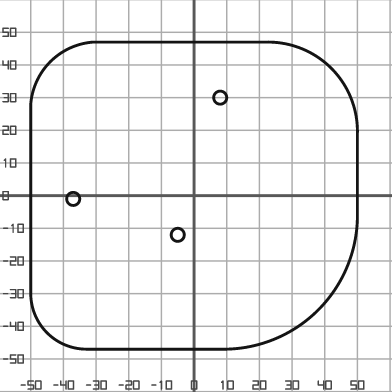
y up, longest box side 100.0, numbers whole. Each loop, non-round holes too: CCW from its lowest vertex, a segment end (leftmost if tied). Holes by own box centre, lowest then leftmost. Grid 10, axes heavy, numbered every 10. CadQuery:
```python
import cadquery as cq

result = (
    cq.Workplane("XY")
    .moveTo(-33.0, -47.0)
    .lineTo(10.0, -47.0)
    .threePointArc((38.0, -35.0), (50.0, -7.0))
    .lineTo(50.0, 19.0)
    .threePointArc((42.0, 39.0), (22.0, 47.0))
    .lineTo(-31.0, 47.0)
    .threePointArc((-44.0, 41.0), (-50.0, 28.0))
    .lineTo(-50.0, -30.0)
    .threePointArc((-45.0, -42.0), (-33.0, -47.0))
    .close()
    .moveTo(-5.0, -12.0)
    .circle(2.0)
    .moveTo(-37.0, -1.0)
    .circle(2.0)
    .moveTo(8.0, 30.0)
    .circle(2.0)
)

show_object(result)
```